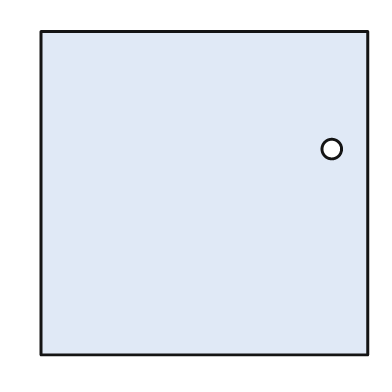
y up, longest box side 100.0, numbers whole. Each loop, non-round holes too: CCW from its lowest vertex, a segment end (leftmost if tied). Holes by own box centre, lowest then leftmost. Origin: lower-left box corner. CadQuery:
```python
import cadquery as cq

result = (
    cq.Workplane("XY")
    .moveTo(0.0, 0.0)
    .lineTo(100.0, 0.0)
    .lineTo(100.0, 99.0)
    .lineTo(0.0, 99.0)
    .close()
    .moveTo(89.0, 63.0)
    .circle(3.0)
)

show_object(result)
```